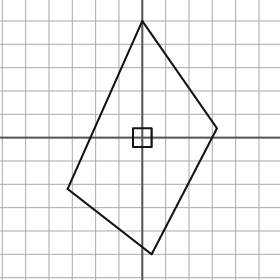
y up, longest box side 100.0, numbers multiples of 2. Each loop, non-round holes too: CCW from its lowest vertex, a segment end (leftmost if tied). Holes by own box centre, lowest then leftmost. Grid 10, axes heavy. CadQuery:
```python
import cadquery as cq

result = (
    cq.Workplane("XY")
    .moveTo(4.0, -50.0)
    .lineTo(32.0, 4.0)
    .lineTo(0.0, 50.0)
    .lineTo(-32.0, -22.0)
    .close()
    .moveTo(-4.0, -4.0)
    .lineTo(4.0, -4.0)
    .lineTo(4.0, 4.0)
    .lineTo(-4.0, 4.0)
    .close()
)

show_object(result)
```